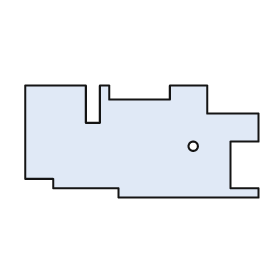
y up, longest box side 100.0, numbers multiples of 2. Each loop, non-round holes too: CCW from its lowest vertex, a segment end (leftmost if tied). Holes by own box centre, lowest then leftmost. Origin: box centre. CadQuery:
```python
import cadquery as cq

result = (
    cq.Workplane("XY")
    .moveTo(-10.0, -24.0)
    .lineTo(50.0, -24.0)
    .lineTo(50.0, -20.0)
    .lineTo(38.0, -20.0)
    .lineTo(38.0, 0.0)
    .lineTo(50.0, 0.0)
    .lineTo(50.0, 12.0)
    .lineTo(28.0, 12.0)
    .lineTo(28.0, 24.0)
    .lineTo(12.0, 24.0)
    .lineTo(12.0, 18.0)
    .lineTo(-14.0, 18.0)
    .lineTo(-14.0, 24.0)
    .lineTo(-18.0, 24.0)
    .lineTo(-18.0, 8.0)
    .lineTo(-24.0, 8.0)
    .lineTo(-24.0, 24.0)
    .lineTo(-50.0, 24.0)
    .lineTo(-50.0, -16.0)
    .lineTo(-38.0, -16.0)
    .lineTo(-38.0, -20.0)
    .lineTo(-10.0, -20.0)
    .close()
    .moveTo(22.0, -2.0)
    .circle(2.0)
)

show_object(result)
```